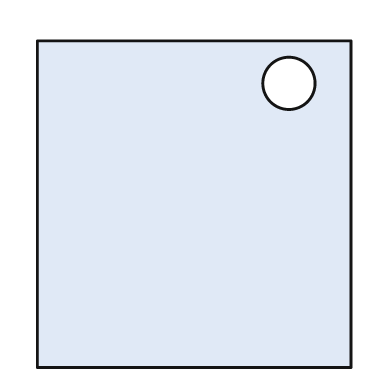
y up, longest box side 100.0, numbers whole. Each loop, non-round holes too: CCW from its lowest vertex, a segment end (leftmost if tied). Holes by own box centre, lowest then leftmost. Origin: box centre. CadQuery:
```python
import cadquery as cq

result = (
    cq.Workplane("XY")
    .moveTo(-48.0, -50.0)
    .lineTo(48.0, -50.0)
    .lineTo(48.0, 50.0)
    .lineTo(-48.0, 50.0)
    .close()
    .moveTo(29.0, 37.0)
    .circle(8.0)
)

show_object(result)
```